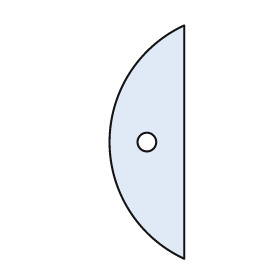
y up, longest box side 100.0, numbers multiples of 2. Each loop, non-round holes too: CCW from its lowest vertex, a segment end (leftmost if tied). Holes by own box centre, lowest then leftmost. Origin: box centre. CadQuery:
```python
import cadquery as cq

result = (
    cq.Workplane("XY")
    .moveTo(16.0, -50.0)
    .lineTo(16.0, 50.0)
    .threePointArc((-16.0, 0.0), (16.0, -50.0))
    .close()
    .moveTo(0.0, 0.0)
    .circle(4.0)
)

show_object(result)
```